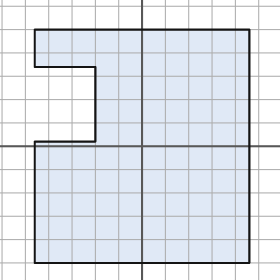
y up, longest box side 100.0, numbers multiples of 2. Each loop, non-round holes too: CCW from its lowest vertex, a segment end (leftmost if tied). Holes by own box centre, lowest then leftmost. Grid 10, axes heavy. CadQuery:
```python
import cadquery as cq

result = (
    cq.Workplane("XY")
    .moveTo(-46.0, -50.0)
    .lineTo(46.0, -50.0)
    .lineTo(46.0, 50.0)
    .lineTo(-46.0, 50.0)
    .lineTo(-46.0, 34.0)
    .lineTo(-20.0, 34.0)
    .lineTo(-20.0, 2.0)
    .lineTo(-46.0, 2.0)
    .close()
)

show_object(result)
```